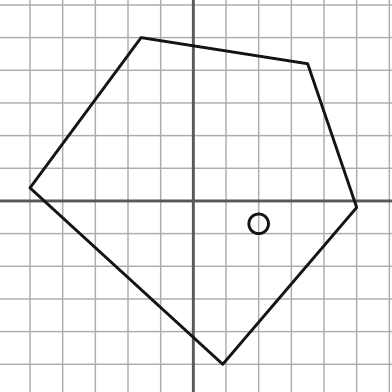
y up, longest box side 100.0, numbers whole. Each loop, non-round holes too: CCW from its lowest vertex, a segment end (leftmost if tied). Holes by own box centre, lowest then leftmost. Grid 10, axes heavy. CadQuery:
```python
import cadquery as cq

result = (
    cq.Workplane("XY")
    .moveTo(9.0, -50.0)
    .lineTo(50.0, -2.0)
    .lineTo(35.0, 42.0)
    .lineTo(-16.0, 50.0)
    .lineTo(-50.0, 4.0)
    .close()
    .moveTo(20.0, -7.0)
    .circle(3.0)
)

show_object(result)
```